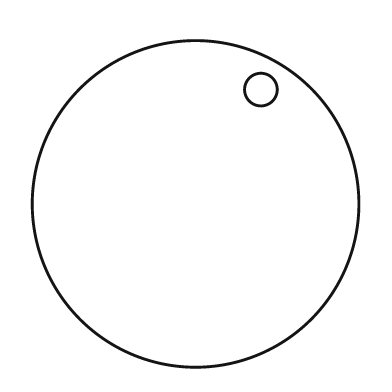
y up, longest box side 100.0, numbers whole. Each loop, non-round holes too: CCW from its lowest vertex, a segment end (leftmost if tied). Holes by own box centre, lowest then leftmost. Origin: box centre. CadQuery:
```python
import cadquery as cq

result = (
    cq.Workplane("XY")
    .moveTo(0.0, 0.0)
    .circle(50.0)
    .moveTo(20.0, 35.0)
    .circle(5.0)
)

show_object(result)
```